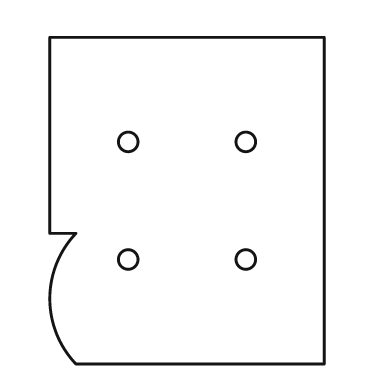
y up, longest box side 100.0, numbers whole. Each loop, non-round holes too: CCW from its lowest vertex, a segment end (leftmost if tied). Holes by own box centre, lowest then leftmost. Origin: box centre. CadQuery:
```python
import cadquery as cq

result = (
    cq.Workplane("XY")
    .moveTo(-34.0, -50.0)
    .lineTo(42.0, -50.0)
    .lineTo(42.0, 50.0)
    .lineTo(-42.0, 50.0)
    .lineTo(-42.0, -10.0)
    .lineTo(-34.0, -10.0)
    .threePointArc((-42.0, -30.0), (-34.0, -50.0))
    .close()
    .moveTo(-18.0, -18.0)
    .circle(3.0)
    .moveTo(18.0, -18.0)
    .circle(3.0)
    .moveTo(-18.0, 18.0)
    .circle(3.0)
    .moveTo(18.0, 18.0)
    .circle(3.0)
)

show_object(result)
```